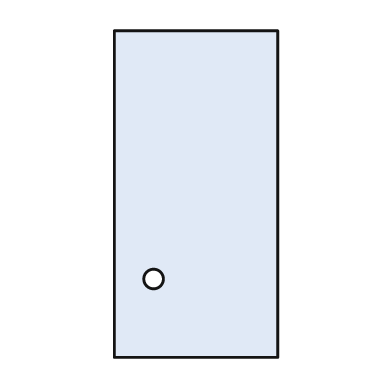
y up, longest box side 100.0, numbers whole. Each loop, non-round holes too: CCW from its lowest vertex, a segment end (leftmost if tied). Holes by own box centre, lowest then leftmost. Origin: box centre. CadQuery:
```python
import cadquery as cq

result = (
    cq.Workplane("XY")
    .moveTo(-25.0, -50.0)
    .lineTo(25.0, -50.0)
    .lineTo(25.0, 50.0)
    .lineTo(-25.0, 50.0)
    .close()
    .moveTo(-13.0, -26.0)
    .circle(3.0)
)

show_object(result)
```